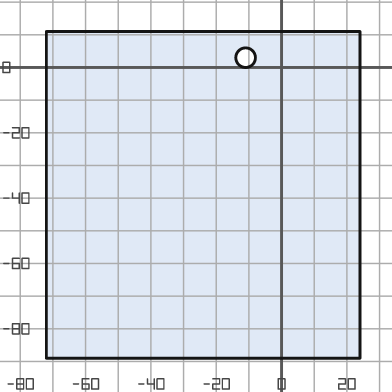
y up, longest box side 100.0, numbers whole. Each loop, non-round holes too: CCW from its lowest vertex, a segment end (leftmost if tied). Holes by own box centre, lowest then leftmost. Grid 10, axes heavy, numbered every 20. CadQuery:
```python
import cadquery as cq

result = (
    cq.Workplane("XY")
    .moveTo(-72.0, -89.0)
    .lineTo(24.0, -89.0)
    .lineTo(24.0, 11.0)
    .lineTo(-72.0, 11.0)
    .close()
    .moveTo(-11.0, 3.0)
    .circle(3.0)
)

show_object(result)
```